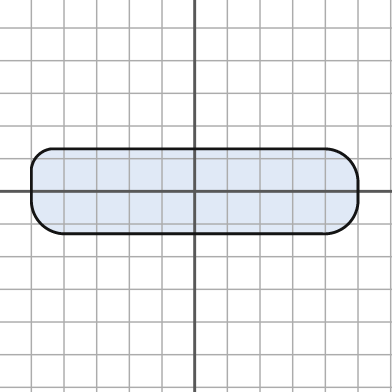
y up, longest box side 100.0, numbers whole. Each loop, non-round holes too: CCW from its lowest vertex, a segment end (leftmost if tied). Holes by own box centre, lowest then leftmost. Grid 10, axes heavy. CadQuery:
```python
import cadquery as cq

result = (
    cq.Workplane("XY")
    .moveTo(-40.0, -13.0)
    .lineTo(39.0, -13.0)
    .threePointArc((47.0, -10.0), (50.0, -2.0))
    .lineTo(50.0, 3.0)
    .threePointArc((47.0, 10.0), (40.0, 13.0))
    .lineTo(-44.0, 13.0)
    .threePointArc((-48.0, 11.0), (-50.0, 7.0))
    .lineTo(-50.0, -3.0)
    .threePointArc((-47.0, -10.0), (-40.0, -13.0))
    .close()
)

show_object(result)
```